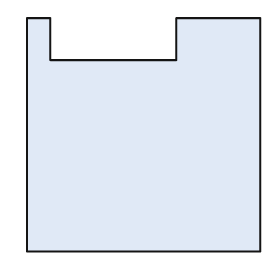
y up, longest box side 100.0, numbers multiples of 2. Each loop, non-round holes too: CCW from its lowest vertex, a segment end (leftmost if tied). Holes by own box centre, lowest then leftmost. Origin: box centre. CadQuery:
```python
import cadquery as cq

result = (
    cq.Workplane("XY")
    .moveTo(-50.0, -50.0)
    .lineTo(50.0, -50.0)
    .lineTo(50.0, 50.0)
    .lineTo(14.0, 50.0)
    .lineTo(14.0, 32.0)
    .lineTo(-40.0, 32.0)
    .lineTo(-40.0, 50.0)
    .lineTo(-50.0, 50.0)
    .close()
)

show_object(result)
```